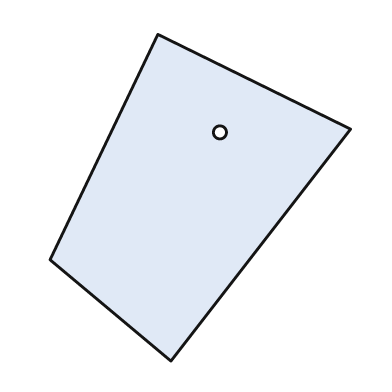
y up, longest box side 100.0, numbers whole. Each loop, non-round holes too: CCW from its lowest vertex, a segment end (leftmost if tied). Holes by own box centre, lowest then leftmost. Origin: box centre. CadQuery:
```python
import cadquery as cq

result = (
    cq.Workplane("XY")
    .moveTo(-9.0, -50.0)
    .lineTo(46.0, 21.0)
    .lineTo(-13.0, 50.0)
    .lineTo(-46.0, -19.0)
    .close()
    .moveTo(6.0, 20.0)
    .circle(2.0)
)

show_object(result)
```